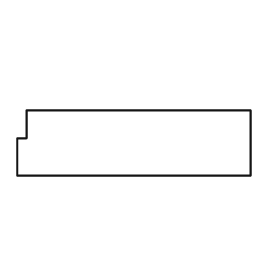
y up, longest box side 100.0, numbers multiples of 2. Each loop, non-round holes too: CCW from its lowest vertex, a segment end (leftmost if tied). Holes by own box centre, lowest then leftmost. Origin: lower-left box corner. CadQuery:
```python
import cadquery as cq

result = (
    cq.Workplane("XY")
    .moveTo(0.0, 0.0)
    .lineTo(100.0, 0.0)
    .lineTo(100.0, 28.0)
    .lineTo(4.0, 28.0)
    .lineTo(4.0, 16.0)
    .lineTo(0.0, 16.0)
    .close()
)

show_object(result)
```